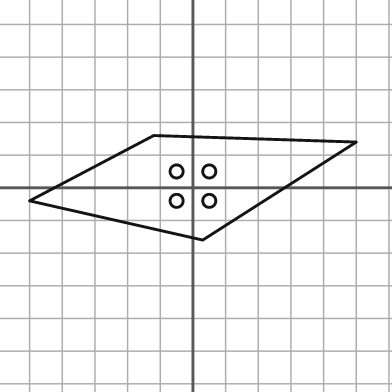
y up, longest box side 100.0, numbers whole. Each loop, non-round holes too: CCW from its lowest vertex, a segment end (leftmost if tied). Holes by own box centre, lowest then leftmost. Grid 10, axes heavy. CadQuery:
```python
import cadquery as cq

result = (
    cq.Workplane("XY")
    .moveTo(3.0, -16.0)
    .lineTo(50.0, 14.0)
    .lineTo(-12.0, 16.0)
    .lineTo(-50.0, -4.0)
    .close()
    .moveTo(-5.0, -4.0)
    .circle(2.0)
    .moveTo(5.0, -4.0)
    .circle(2.0)
    .moveTo(-5.0, 5.0)
    .circle(2.0)
    .moveTo(5.0, 5.0)
    .circle(2.0)
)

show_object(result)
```